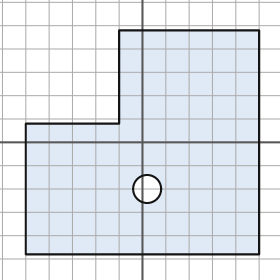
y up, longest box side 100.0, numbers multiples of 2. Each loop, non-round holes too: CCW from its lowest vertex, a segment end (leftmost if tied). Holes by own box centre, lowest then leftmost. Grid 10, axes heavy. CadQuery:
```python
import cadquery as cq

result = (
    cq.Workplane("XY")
    .moveTo(-50.0, -48.0)
    .lineTo(50.0, -48.0)
    .lineTo(50.0, 48.0)
    .lineTo(-10.0, 48.0)
    .lineTo(-10.0, 8.0)
    .lineTo(-50.0, 8.0)
    .close()
    .moveTo(2.0, -20.0)
    .circle(6.0)
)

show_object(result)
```